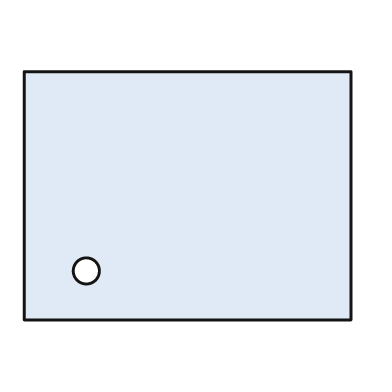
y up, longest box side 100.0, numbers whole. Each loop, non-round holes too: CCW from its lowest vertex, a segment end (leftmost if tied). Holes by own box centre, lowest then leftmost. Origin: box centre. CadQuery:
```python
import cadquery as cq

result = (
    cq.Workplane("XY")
    .moveTo(-50.0, -38.0)
    .lineTo(50.0, -38.0)
    .lineTo(50.0, 38.0)
    .lineTo(-50.0, 38.0)
    .close()
    .moveTo(-31.0, -23.0)
    .circle(4.0)
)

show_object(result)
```